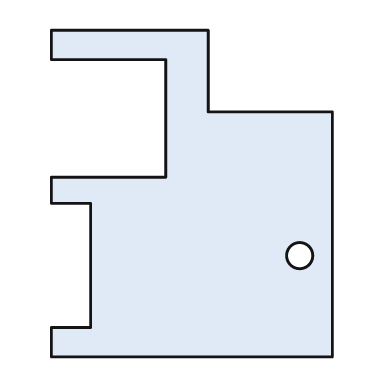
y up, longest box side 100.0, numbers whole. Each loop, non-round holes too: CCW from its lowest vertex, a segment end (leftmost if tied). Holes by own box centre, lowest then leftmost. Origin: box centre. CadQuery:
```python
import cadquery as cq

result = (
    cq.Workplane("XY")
    .moveTo(-43.0, -50.0)
    .lineTo(43.0, -50.0)
    .lineTo(43.0, 25.0)
    .lineTo(5.0, 25.0)
    .lineTo(5.0, 50.0)
    .lineTo(-43.0, 50.0)
    .lineTo(-43.0, 41.0)
    .lineTo(-8.0, 41.0)
    .lineTo(-8.0, 5.0)
    .lineTo(-43.0, 5.0)
    .lineTo(-43.0, -3.0)
    .lineTo(-31.0, -3.0)
    .lineTo(-31.0, -41.0)
    .lineTo(-43.0, -41.0)
    .close()
    .moveTo(33.0, -19.0)
    .circle(4.0)
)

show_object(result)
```